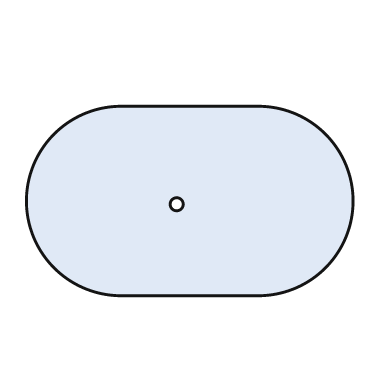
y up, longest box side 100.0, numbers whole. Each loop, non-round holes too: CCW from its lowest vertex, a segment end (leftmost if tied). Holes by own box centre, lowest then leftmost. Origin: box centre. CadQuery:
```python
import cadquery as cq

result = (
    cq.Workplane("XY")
    .moveTo(-21.0, -29.0)
    .lineTo(21.0, -29.0)
    .threePointArc((50.0, 0.0), (21.0, 29.0))
    .lineTo(-21.0, 29.0)
    .threePointArc((-50.0, 0.0), (-21.0, -29.0))
    .close()
    .moveTo(-4.0, -1.0)
    .circle(2.0)
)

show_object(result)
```